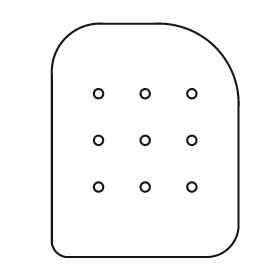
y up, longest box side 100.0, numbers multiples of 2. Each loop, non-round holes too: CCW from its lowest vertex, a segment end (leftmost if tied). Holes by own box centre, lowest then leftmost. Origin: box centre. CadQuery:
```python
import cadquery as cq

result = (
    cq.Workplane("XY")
    .moveTo(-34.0, -50.0)
    .lineTo(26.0, -50.0)
    .threePointArc((36.0, -46.0), (40.0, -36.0))
    .lineTo(40.0, 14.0)
    .threePointArc((30.0, 40.0), (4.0, 50.0))
    .lineTo(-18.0, 50.0)
    .threePointArc((-34.0, 44.0), (-40.0, 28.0))
    .lineTo(-40.0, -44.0)
    .threePointArc((-38.0, -48.0), (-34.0, -50.0))
    .close()
    .moveTo(-20.0, -20.0)
    .circle(2.0)
    .moveTo(0.0, -20.0)
    .circle(2.0)
    .moveTo(20.0, -20.0)
    .circle(2.0)
    .moveTo(-20.0, 0.0)
    .circle(2.0)
    .moveTo(0.0, 0.0)
    .circle(2.0)
    .moveTo(20.0, 0.0)
    .circle(2.0)
    .moveTo(-20.0, 20.0)
    .circle(2.0)
    .moveTo(0.0, 20.0)
    .circle(2.0)
    .moveTo(20.0, 20.0)
    .circle(2.0)
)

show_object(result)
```